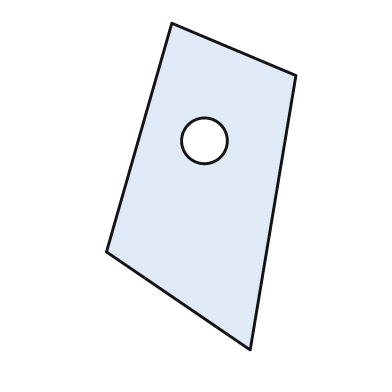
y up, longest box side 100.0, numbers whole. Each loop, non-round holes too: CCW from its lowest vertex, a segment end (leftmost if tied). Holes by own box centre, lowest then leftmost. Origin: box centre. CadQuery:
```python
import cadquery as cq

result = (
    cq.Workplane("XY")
    .moveTo(15.0, -50.0)
    .lineTo(29.0, 34.0)
    .lineTo(-9.0, 50.0)
    .lineTo(-29.0, -20.0)
    .close()
    .moveTo(1.0, 14.0)
    .circle(7.0)
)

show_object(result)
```